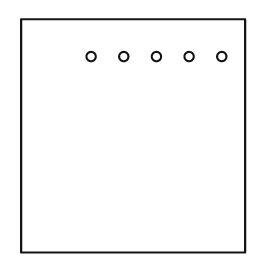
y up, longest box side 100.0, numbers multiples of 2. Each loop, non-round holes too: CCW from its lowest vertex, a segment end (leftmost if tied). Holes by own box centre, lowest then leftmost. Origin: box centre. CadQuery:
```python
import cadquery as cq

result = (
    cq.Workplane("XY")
    .moveTo(-48.0, -50.0)
    .lineTo(48.0, -50.0)
    .lineTo(48.0, 50.0)
    .lineTo(-48.0, 50.0)
    .close()
    .moveTo(-18.0, 34.0)
    .circle(2.0)
    .moveTo(-4.0, 34.0)
    .circle(2.0)
    .moveTo(10.0, 34.0)
    .circle(2.0)
    .moveTo(24.0, 34.0)
    .circle(2.0)
    .moveTo(38.0, 34.0)
    .circle(2.0)
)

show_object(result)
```